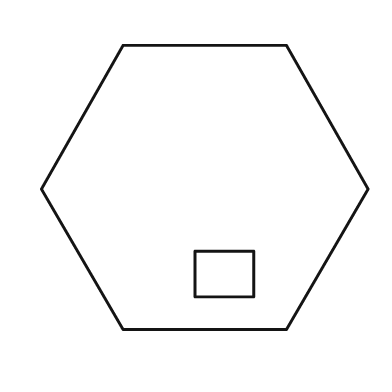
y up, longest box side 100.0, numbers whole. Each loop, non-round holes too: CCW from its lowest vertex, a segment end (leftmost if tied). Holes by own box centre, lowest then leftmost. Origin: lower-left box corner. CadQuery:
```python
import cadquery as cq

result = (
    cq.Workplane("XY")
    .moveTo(25.0, 0.0)
    .lineTo(75.0, 0.0)
    .lineTo(100.0, 43.0)
    .lineTo(75.0, 87.0)
    .lineTo(25.0, 87.0)
    .lineTo(0.0, 43.0)
    .close()
    .moveTo(47.0, 10.0)
    .lineTo(65.0, 10.0)
    .lineTo(65.0, 24.0)
    .lineTo(47.0, 24.0)
    .close()
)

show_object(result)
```